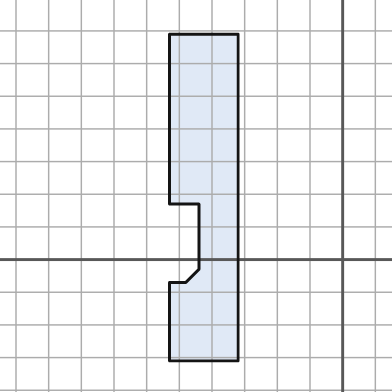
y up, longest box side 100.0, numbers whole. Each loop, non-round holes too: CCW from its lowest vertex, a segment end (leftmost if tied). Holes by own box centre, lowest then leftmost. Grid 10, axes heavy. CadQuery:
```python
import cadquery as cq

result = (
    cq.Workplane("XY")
    .moveTo(-53.0, -31.0)
    .lineTo(-32.0, -31.0)
    .lineTo(-32.0, 69.0)
    .lineTo(-53.0, 69.0)
    .lineTo(-53.0, 17.0)
    .lineTo(-44.0, 17.0)
    .lineTo(-44.0, -3.0)
    .lineTo(-48.0, -7.0)
    .lineTo(-53.0, -7.0)
    .close()
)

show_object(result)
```